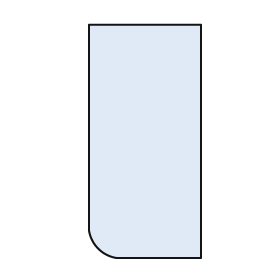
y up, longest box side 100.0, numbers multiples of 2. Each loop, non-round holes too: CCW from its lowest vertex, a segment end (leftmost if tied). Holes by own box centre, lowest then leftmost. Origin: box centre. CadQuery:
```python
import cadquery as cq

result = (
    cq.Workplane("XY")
    .moveTo(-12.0, -50.0)
    .lineTo(24.0, -50.0)
    .lineTo(24.0, 50.0)
    .lineTo(-24.0, 50.0)
    .lineTo(-24.0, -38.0)
    .threePointArc((-20.0, -46.0), (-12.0, -50.0))
    .close()
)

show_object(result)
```